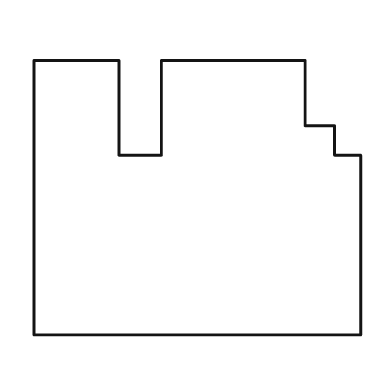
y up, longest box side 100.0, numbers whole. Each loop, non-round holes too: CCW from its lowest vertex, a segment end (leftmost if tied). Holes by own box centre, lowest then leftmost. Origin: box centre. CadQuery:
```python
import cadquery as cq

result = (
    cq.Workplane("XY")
    .moveTo(-50.0, -42.0)
    .lineTo(50.0, -42.0)
    .lineTo(50.0, 13.0)
    .lineTo(42.0, 13.0)
    .lineTo(42.0, 22.0)
    .lineTo(33.0, 22.0)
    .lineTo(33.0, 42.0)
    .lineTo(-11.0, 42.0)
    .lineTo(-11.0, 13.0)
    .lineTo(-24.0, 13.0)
    .lineTo(-24.0, 42.0)
    .lineTo(-50.0, 42.0)
    .close()
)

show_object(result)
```